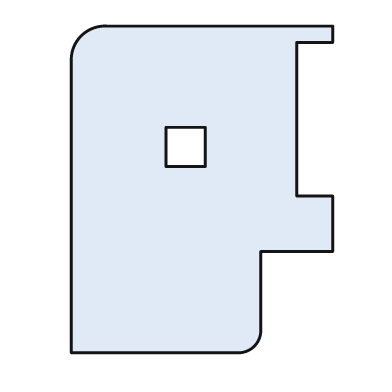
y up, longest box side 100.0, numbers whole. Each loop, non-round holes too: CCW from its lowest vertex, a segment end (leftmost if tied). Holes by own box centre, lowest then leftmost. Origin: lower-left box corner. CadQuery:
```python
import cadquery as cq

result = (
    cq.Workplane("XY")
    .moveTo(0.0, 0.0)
    .lineTo(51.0, 0.0)
    .threePointArc((56.0, 2.0), (58.0, 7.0))
    .lineTo(58.0, 31.0)
    .lineTo(80.0, 31.0)
    .lineTo(80.0, 48.0)
    .lineTo(69.0, 48.0)
    .lineTo(69.0, 95.0)
    .lineTo(80.0, 95.0)
    .lineTo(80.0, 100.0)
    .lineTo(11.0, 100.0)
    .threePointArc((3.0, 97.0), (0.0, 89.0))
    .close()
    .moveTo(29.0, 57.0)
    .lineTo(41.0, 57.0)
    .lineTo(41.0, 69.0)
    .lineTo(29.0, 69.0)
    .close()
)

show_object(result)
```